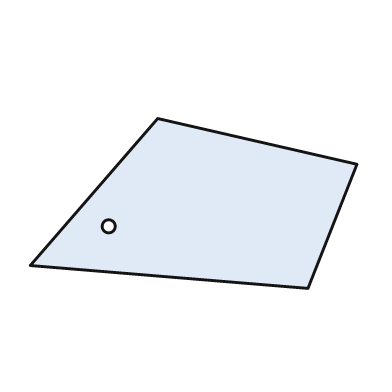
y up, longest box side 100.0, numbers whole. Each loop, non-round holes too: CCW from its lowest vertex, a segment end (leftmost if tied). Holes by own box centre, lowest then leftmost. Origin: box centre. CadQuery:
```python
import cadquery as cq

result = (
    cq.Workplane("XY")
    .moveTo(35.0, -26.0)
    .lineTo(50.0, 12.0)
    .lineTo(-11.0, 26.0)
    .lineTo(-50.0, -19.0)
    .close()
    .moveTo(-26.0, -7.0)
    .circle(2.0)
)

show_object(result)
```